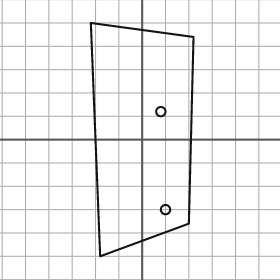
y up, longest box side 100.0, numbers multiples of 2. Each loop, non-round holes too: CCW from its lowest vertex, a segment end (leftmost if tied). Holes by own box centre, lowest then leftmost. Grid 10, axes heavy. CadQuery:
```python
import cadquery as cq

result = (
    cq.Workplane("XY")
    .moveTo(-18.0, -50.0)
    .lineTo(20.0, -36.0)
    .lineTo(22.0, 44.0)
    .lineTo(-22.0, 50.0)
    .close()
    .moveTo(10.0, -30.0)
    .circle(2.0)
    .moveTo(8.0, 12.0)
    .circle(2.0)
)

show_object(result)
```